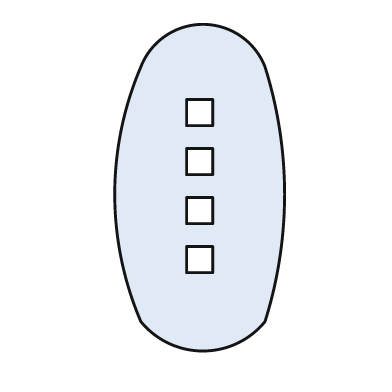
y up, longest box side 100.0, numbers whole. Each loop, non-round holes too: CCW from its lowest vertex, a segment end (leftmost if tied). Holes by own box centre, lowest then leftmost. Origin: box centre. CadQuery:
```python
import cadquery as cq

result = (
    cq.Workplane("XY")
    .moveTo(-18.0, -41.0)
    .threePointArc((1.0, -50.0), (20.0, -41.0))
    .threePointArc((26.0, -2.0), (20.0, 37.0))
    .threePointArc((1.0, 50.0), (-18.0, 37.0))
    .threePointArc((-26.0, -2.0), (-18.0, -41.0))
    .close()
    .moveTo(-4.0, -26.0)
    .lineTo(4.0, -26.0)
    .lineTo(4.0, -18.0)
    .lineTo(-4.0, -18.0)
    .close()
    .moveTo(-4.0, -11.0)
    .lineTo(4.0, -11.0)
    .lineTo(4.0, -3.0)
    .lineTo(-4.0, -3.0)
    .close()
    .moveTo(-4.0, 4.0)
    .lineTo(4.0, 4.0)
    .lineTo(4.0, 12.0)
    .lineTo(-4.0, 12.0)
    .close()
    .moveTo(-4.0, 19.0)
    .lineTo(4.0, 19.0)
    .lineTo(4.0, 27.0)
    .lineTo(-4.0, 27.0)
    .close()
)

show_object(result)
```